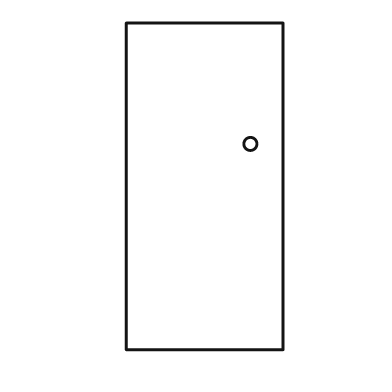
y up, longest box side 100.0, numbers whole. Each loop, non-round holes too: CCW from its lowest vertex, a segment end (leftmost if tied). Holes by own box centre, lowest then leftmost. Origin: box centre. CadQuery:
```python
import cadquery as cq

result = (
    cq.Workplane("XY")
    .moveTo(-24.0, -50.0)
    .lineTo(24.0, -50.0)
    .lineTo(24.0, 50.0)
    .lineTo(-24.0, 50.0)
    .close()
    .moveTo(14.0, 13.0)
    .circle(2.0)
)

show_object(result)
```